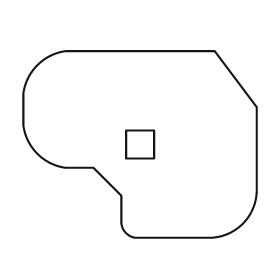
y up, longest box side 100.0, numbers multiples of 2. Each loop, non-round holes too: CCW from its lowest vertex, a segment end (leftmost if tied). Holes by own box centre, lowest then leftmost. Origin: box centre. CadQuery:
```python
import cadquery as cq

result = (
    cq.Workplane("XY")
    .moveTo(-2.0, -40.0)
    .lineTo(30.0, -40.0)
    .threePointArc((44.0, -34.0), (50.0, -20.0))
    .lineTo(50.0, 16.0)
    .lineTo(32.0, 40.0)
    .lineTo(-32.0, 40.0)
    .threePointArc((-44.0, 34.0), (-50.0, 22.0))
    .lineTo(-50.0, 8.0)
    .threePointArc((-44.0, -4.0), (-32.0, -10.0))
    .lineTo(-20.0, -10.0)
    .lineTo(-8.0, -22.0)
    .lineTo(-8.0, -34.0)
    .threePointArc((-6.0, -38.0), (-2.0, -40.0))
    .close()
    .moveTo(-6.0, -6.0)
    .lineTo(6.0, -6.0)
    .lineTo(6.0, 6.0)
    .lineTo(-6.0, 6.0)
    .close()
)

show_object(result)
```